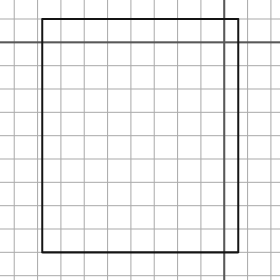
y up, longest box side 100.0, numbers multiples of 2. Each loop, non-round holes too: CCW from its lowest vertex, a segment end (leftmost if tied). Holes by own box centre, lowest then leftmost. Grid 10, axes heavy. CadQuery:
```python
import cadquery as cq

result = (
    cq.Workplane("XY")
    .moveTo(-78.0, -90.0)
    .lineTo(6.0, -90.0)
    .lineTo(6.0, 10.0)
    .lineTo(-78.0, 10.0)
    .close()
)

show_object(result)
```